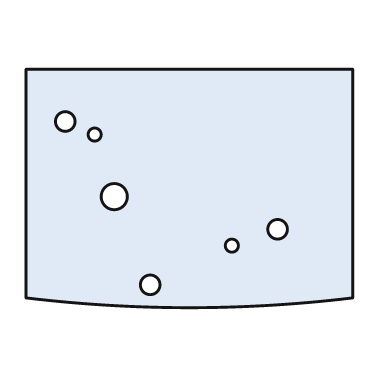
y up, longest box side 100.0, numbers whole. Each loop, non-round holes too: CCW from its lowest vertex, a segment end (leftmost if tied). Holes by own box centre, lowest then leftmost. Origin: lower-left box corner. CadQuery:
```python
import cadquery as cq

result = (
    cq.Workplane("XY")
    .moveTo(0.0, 3.0)
    .threePointArc((50.0, 0.0), (100.0, 3.0))
    .lineTo(100.0, 73.0)
    .lineTo(0.0, 73.0)
    .close()
    .moveTo(38.0, 7.0)
    .circle(3.0)
    .moveTo(63.0, 19.0)
    .circle(2.0)
    .moveTo(77.0, 24.0)
    .circle(3.0)
    .moveTo(27.0, 34.0)
    .circle(4.0)
    .moveTo(21.0, 53.0)
    .circle(2.0)
    .moveTo(12.0, 57.0)
    .circle(3.0)
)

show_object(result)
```